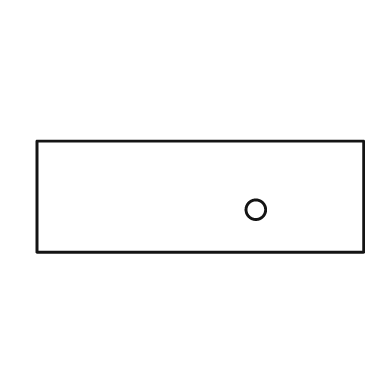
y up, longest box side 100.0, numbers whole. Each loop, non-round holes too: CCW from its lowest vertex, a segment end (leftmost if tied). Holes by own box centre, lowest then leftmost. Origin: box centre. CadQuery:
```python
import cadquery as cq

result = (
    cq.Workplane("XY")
    .moveTo(-50.0, -17.0)
    .lineTo(50.0, -17.0)
    .lineTo(50.0, 17.0)
    .lineTo(-50.0, 17.0)
    .close()
    .moveTo(17.0, -4.0)
    .circle(3.0)
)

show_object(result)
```